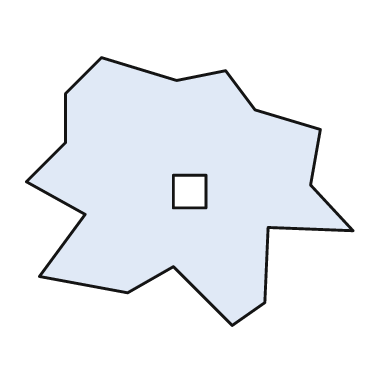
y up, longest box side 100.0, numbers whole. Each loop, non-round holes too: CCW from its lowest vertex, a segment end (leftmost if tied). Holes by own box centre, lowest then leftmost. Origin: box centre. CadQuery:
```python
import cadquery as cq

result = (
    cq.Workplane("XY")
    .moveTo(13.0, -41.0)
    .lineTo(23.0, -34.0)
    .lineTo(24.0, -11.0)
    .lineTo(50.0, -12.0)
    .lineTo(37.0, 2.0)
    .lineTo(40.0, 19.0)
    .lineTo(20.0, 25.0)
    .lineTo(11.0, 37.0)
    .lineTo(-4.0, 34.0)
    .lineTo(-27.0, 41.0)
    .lineTo(-38.0, 30.0)
    .lineTo(-38.0, 15.0)
    .lineTo(-50.0, 3.0)
    .lineTo(-32.0, -7.0)
    .lineTo(-46.0, -26.0)
    .lineTo(-19.0, -31.0)
    .lineTo(-5.0, -23.0)
    .close()
    .moveTo(-5.0, -5.0)
    .lineTo(5.0, -5.0)
    .lineTo(5.0, 5.0)
    .lineTo(-5.0, 5.0)
    .close()
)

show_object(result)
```